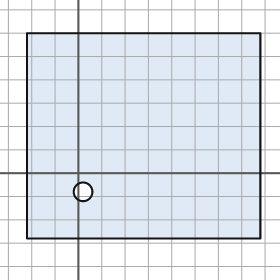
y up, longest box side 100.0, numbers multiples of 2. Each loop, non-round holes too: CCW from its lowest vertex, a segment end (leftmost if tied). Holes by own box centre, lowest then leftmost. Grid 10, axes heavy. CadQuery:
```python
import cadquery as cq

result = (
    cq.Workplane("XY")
    .moveTo(-22.0, -28.0)
    .lineTo(78.0, -28.0)
    .lineTo(78.0, 60.0)
    .lineTo(-22.0, 60.0)
    .close()
    .moveTo(2.0, -8.0)
    .circle(4.0)
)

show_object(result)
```